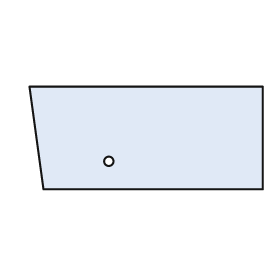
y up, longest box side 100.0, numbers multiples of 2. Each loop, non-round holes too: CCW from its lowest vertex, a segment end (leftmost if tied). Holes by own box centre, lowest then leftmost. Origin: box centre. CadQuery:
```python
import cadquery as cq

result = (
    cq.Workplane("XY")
    .moveTo(-44.0, -22.0)
    .lineTo(50.0, -22.0)
    .lineTo(50.0, 22.0)
    .lineTo(-50.0, 22.0)
    .close()
    .moveTo(-16.0, -10.0)
    .circle(2.0)
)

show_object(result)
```